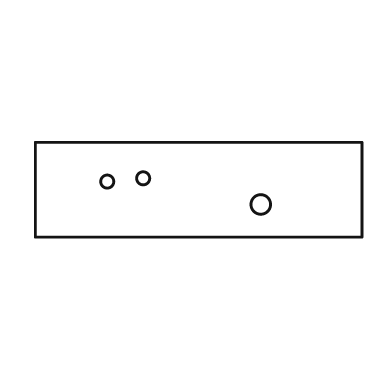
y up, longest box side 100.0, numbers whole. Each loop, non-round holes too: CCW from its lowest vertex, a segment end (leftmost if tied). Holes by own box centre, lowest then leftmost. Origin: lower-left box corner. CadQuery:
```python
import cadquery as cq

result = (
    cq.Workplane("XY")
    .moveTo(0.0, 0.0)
    .lineTo(100.0, 0.0)
    .lineTo(100.0, 29.0)
    .lineTo(0.0, 29.0)
    .close()
    .moveTo(69.0, 10.0)
    .circle(3.0)
    .moveTo(22.0, 17.0)
    .circle(2.0)
    .moveTo(33.0, 18.0)
    .circle(2.0)
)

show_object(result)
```